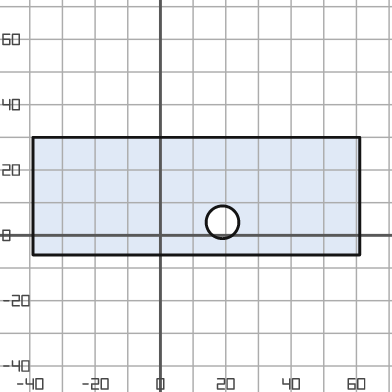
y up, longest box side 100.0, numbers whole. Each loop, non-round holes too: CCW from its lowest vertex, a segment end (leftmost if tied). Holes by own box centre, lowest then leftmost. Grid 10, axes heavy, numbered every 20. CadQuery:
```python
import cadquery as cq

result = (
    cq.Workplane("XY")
    .moveTo(-39.0, -6.0)
    .lineTo(61.0, -6.0)
    .lineTo(61.0, 30.0)
    .lineTo(-39.0, 30.0)
    .close()
    .moveTo(19.0, 4.0)
    .circle(5.0)
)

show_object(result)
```